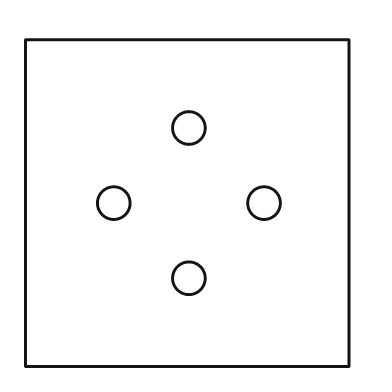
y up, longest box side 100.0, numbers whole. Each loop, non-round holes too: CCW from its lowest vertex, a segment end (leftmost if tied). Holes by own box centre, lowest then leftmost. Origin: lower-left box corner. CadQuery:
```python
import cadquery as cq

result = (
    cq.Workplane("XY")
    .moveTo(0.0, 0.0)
    .lineTo(99.0, 0.0)
    .lineTo(99.0, 100.0)
    .lineTo(0.0, 100.0)
    .close()
    .moveTo(50.0, 27.0)
    .circle(5.0)
    .moveTo(27.0, 50.0)
    .circle(5.0)
    .moveTo(73.0, 50.0)
    .circle(5.0)
    .moveTo(50.0, 73.0)
    .circle(5.0)
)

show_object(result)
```